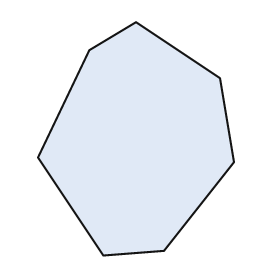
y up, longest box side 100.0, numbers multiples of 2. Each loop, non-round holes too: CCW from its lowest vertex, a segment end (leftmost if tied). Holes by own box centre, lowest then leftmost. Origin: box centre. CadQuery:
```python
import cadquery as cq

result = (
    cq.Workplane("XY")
    .moveTo(-14.0, -50.0)
    .lineTo(12.0, -48.0)
    .lineTo(42.0, -10.0)
    .lineTo(36.0, 26.0)
    .lineTo(0.0, 50.0)
    .lineTo(-20.0, 38.0)
    .lineTo(-42.0, -8.0)
    .close()
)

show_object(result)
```